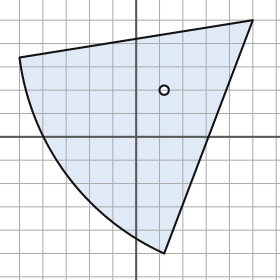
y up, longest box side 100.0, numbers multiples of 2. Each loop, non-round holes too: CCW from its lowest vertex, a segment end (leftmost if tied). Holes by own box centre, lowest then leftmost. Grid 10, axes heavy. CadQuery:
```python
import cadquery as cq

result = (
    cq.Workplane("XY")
    .moveTo(12.0, -50.0)
    .lineTo(50.0, 50.0)
    .lineTo(-50.0, 34.0)
    .threePointArc((-30.0, -16.0), (12.0, -50.0))
    .close()
    .moveTo(12.0, 20.0)
    .circle(2.0)
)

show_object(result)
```